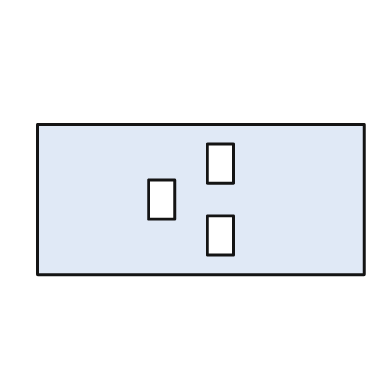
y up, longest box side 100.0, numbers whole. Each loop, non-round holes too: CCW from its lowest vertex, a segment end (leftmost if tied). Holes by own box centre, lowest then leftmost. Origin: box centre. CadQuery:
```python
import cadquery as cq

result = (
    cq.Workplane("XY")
    .moveTo(-50.0, -23.0)
    .lineTo(50.0, -23.0)
    .lineTo(50.0, 23.0)
    .lineTo(-50.0, 23.0)
    .close()
    .moveTo(2.0, -17.0)
    .lineTo(10.0, -17.0)
    .lineTo(10.0, -5.0)
    .lineTo(2.0, -5.0)
    .close()
    .moveTo(-16.0, -6.0)
    .lineTo(-8.0, -6.0)
    .lineTo(-8.0, 6.0)
    .lineTo(-16.0, 6.0)
    .close()
    .moveTo(2.0, 5.0)
    .lineTo(10.0, 5.0)
    .lineTo(10.0, 17.0)
    .lineTo(2.0, 17.0)
    .close()
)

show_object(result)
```